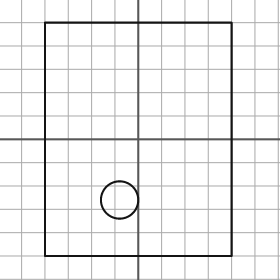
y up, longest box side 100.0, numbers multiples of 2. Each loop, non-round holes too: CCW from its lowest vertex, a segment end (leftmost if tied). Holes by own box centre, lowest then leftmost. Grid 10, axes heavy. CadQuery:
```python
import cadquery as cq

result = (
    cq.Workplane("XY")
    .moveTo(-40.0, -50.0)
    .lineTo(40.0, -50.0)
    .lineTo(40.0, 50.0)
    .lineTo(-40.0, 50.0)
    .close()
    .moveTo(-8.0, -26.0)
    .circle(8.0)
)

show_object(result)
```